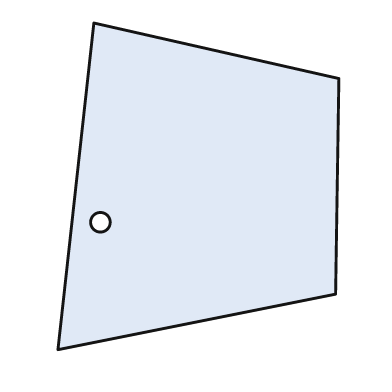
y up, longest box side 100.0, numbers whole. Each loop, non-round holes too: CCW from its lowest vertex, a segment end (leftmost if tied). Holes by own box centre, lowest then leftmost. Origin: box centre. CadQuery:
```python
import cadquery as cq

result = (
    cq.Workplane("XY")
    .moveTo(-43.0, -50.0)
    .lineTo(42.0, -33.0)
    .lineTo(43.0, 33.0)
    .lineTo(-32.0, 50.0)
    .close()
    .moveTo(-30.0, -11.0)
    .circle(3.0)
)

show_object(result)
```